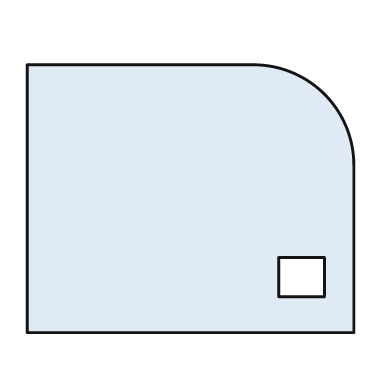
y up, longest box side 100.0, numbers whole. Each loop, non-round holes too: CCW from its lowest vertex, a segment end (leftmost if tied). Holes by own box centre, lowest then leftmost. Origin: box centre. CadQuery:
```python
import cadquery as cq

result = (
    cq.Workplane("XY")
    .moveTo(-50.0, -41.0)
    .lineTo(50.0, -41.0)
    .lineTo(50.0, 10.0)
    .threePointArc((41.0, 32.0), (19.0, 41.0))
    .lineTo(-50.0, 41.0)
    .close()
    .moveTo(27.0, -30.0)
    .lineTo(41.0, -30.0)
    .lineTo(41.0, -18.0)
    .lineTo(27.0, -18.0)
    .close()
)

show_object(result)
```